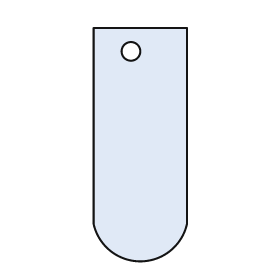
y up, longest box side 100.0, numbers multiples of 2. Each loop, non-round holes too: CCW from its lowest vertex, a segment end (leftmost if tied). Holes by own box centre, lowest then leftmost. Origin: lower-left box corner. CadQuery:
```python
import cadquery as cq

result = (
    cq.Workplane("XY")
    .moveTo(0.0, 16.0)
    .threePointArc((20.0, 0.0), (40.0, 16.0))
    .lineTo(40.0, 100.0)
    .lineTo(0.0, 100.0)
    .close()
    .moveTo(16.0, 90.0)
    .circle(4.0)
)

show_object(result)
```